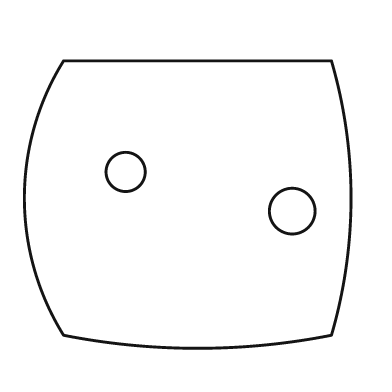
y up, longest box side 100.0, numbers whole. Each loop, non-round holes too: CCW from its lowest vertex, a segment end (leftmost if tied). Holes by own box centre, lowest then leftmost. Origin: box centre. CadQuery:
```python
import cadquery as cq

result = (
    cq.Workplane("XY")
    .moveTo(-38.0, -40.0)
    .threePointArc((3.0, -44.0), (44.0, -40.0))
    .threePointArc((50.0, 2.0), (44.0, 44.0))
    .lineTo(-38.0, 44.0)
    .threePointArc((-50.0, 2.0), (-38.0, -40.0))
    .close()
    .moveTo(32.0, -2.0)
    .circle(7.0)
    .moveTo(-19.0, 10.0)
    .circle(6.0)
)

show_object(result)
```